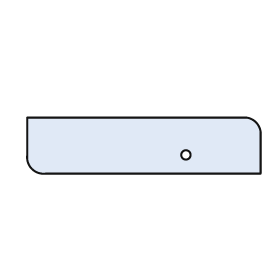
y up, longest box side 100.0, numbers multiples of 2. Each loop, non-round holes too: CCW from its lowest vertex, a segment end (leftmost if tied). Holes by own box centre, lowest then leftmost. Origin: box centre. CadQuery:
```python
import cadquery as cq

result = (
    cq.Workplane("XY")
    .moveTo(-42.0, -12.0)
    .lineTo(50.0, -12.0)
    .lineTo(50.0, 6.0)
    .threePointArc((48.0, 10.0), (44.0, 12.0))
    .lineTo(-50.0, 12.0)
    .lineTo(-50.0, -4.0)
    .threePointArc((-48.0, -10.0), (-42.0, -12.0))
    .close()
    .moveTo(18.0, -4.0)
    .circle(2.0)
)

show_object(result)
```